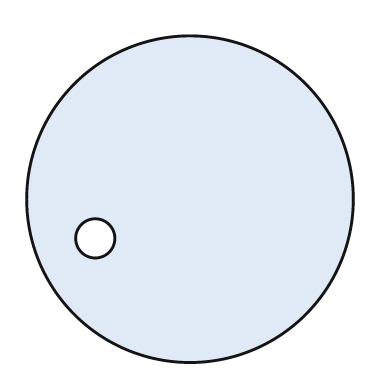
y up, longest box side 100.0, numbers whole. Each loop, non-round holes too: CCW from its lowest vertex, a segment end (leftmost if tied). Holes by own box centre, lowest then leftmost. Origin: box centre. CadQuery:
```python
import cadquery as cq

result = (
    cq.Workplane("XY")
    .moveTo(0.0, 0.0)
    .circle(50.0)
    .moveTo(-29.0, -12.0)
    .circle(6.0)
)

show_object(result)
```